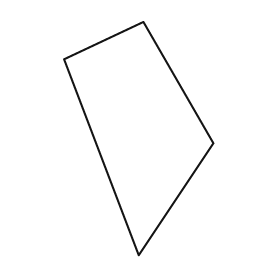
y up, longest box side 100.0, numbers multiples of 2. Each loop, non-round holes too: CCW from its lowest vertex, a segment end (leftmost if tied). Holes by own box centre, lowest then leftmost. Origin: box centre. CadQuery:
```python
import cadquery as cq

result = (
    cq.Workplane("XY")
    .moveTo(0.0, -50.0)
    .lineTo(32.0, -2.0)
    .lineTo(2.0, 50.0)
    .lineTo(-32.0, 34.0)
    .close()
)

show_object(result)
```